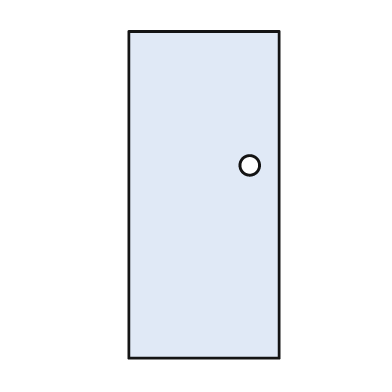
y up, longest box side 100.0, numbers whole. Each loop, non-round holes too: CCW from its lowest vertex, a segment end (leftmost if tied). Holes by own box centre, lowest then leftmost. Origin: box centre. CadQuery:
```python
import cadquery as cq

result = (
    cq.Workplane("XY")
    .moveTo(-23.0, -50.0)
    .lineTo(23.0, -50.0)
    .lineTo(23.0, 50.0)
    .lineTo(-23.0, 50.0)
    .close()
    .moveTo(14.0, 9.0)
    .circle(3.0)
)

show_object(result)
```